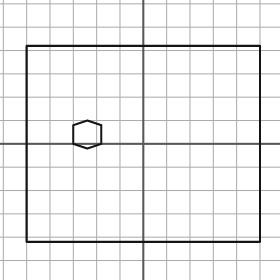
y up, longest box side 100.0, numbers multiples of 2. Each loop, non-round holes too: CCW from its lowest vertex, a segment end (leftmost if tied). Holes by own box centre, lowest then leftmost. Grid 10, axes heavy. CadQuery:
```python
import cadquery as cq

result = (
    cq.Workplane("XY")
    .moveTo(-50.0, -42.0)
    .lineTo(50.0, -42.0)
    .lineTo(50.0, 42.0)
    .lineTo(-50.0, 42.0)
    .close()
    .moveTo(-24.0, -2.0)
    .lineTo(-18.0, 0.0)
    .lineTo(-18.0, 8.0)
    .lineTo(-24.0, 10.0)
    .lineTo(-30.0, 8.0)
    .lineTo(-30.0, 0.0)
    .close()
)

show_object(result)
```